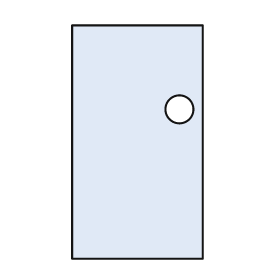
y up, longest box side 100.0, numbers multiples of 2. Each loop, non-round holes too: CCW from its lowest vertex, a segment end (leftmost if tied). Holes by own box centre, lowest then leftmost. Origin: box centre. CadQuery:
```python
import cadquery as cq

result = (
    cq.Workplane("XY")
    .moveTo(-28.0, -50.0)
    .lineTo(28.0, -50.0)
    .lineTo(28.0, 50.0)
    .lineTo(-28.0, 50.0)
    .close()
    .moveTo(18.0, 14.0)
    .circle(6.0)
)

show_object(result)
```